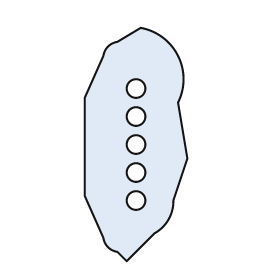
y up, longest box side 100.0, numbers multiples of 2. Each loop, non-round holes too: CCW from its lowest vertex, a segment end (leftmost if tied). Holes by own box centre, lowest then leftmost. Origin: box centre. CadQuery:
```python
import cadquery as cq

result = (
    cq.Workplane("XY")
    .moveTo(-4.0, -50.0)
    .lineTo(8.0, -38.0)
    .threePointArc((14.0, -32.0), (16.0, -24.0))
    .lineTo(22.0, -6.0)
    .lineTo(18.0, 18.0)
    .threePointArc((18.0, 38.0), (2.0, 50.0))
    .lineTo(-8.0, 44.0)
    .threePointArc((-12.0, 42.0), (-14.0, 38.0))
    .lineTo(-22.0, 20.0)
    .lineTo(-22.0, -22.0)
    .lineTo(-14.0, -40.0)
    .threePointArc((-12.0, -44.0), (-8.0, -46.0))
    .close()
    .moveTo(0.0, -24.0)
    .circle(4.0)
    .moveTo(0.0, -12.0)
    .circle(4.0)
    .moveTo(0.0, 0.0)
    .circle(4.0)
    .moveTo(0.0, 12.0)
    .circle(4.0)
    .moveTo(0.0, 24.0)
    .circle(4.0)
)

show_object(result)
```